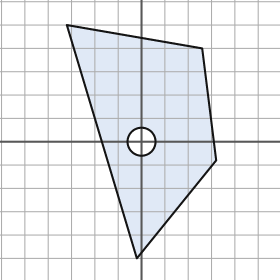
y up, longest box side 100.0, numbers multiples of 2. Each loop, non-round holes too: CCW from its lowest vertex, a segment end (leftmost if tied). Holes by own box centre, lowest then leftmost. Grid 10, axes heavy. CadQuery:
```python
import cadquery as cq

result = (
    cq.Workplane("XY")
    .moveTo(-2.0, -50.0)
    .lineTo(32.0, -8.0)
    .lineTo(26.0, 40.0)
    .lineTo(-32.0, 50.0)
    .close()
    .moveTo(0.0, 0.0)
    .circle(6.0)
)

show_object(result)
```